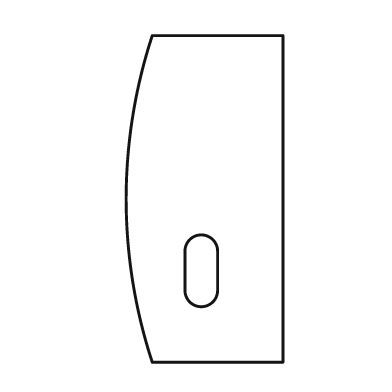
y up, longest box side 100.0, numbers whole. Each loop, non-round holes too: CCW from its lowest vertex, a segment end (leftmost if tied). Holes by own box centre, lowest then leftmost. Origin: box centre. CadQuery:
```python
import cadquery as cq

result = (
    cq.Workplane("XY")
    .moveTo(-16.0, -50.0)
    .lineTo(24.0, -50.0)
    .lineTo(24.0, 50.0)
    .lineTo(-16.0, 50.0)
    .threePointArc((-24.0, 0.0), (-16.0, -50.0))
    .close()
    .moveTo(-6.0, -28.0)
    .threePointArc((-1.0, -33.0), (4.0, -28.0))
    .lineTo(4.0, -16.0)
    .threePointArc((-1.0, -11.0), (-6.0, -16.0))
    .close()
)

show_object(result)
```